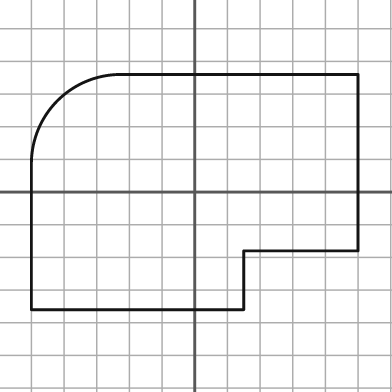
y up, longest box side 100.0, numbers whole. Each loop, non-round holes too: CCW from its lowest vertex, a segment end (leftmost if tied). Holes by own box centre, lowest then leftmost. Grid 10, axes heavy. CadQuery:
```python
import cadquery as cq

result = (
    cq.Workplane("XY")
    .moveTo(-50.0, -36.0)
    .lineTo(15.0, -36.0)
    .lineTo(15.0, -18.0)
    .lineTo(50.0, -18.0)
    .lineTo(50.0, 36.0)
    .lineTo(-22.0, 36.0)
    .threePointArc((-42.0, 28.0), (-50.0, 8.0))
    .close()
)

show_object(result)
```